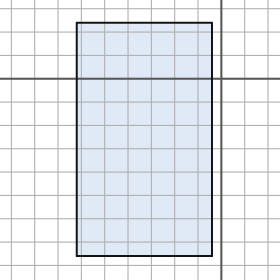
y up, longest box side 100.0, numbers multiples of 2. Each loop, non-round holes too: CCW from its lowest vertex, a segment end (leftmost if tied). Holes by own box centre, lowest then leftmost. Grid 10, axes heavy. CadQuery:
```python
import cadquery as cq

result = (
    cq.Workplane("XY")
    .moveTo(-62.0, -76.0)
    .lineTo(-4.0, -76.0)
    .lineTo(-4.0, 24.0)
    .lineTo(-62.0, 24.0)
    .close()
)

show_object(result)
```